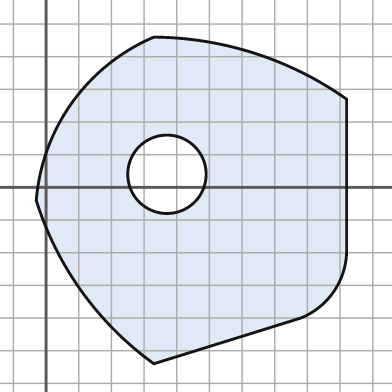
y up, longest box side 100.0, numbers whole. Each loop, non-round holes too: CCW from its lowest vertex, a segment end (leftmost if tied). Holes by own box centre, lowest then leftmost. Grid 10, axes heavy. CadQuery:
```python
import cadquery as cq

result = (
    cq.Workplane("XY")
    .moveTo(33.0, -54.0)
    .lineTo(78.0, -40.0)
    .threePointArc((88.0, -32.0), (92.0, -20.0))
    .lineTo(92.0, 27.0)
    .threePointArc((64.0, 41.0), (33.0, 46.0))
    .threePointArc((8.0, 26.0), (-3.0, -4.0))
    .threePointArc((11.0, -32.0), (33.0, -54.0))
    .close()
    .moveTo(37.0, 4.0)
    .circle(12.0)
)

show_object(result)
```